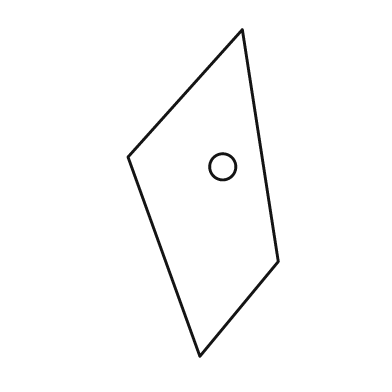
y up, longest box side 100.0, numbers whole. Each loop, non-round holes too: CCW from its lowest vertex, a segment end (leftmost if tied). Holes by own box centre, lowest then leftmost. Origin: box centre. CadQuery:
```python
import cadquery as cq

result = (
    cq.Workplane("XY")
    .moveTo(-1.0, -50.0)
    .lineTo(23.0, -21.0)
    .lineTo(12.0, 50.0)
    .lineTo(-23.0, 11.0)
    .close()
    .moveTo(6.0, 8.0)
    .circle(4.0)
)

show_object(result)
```